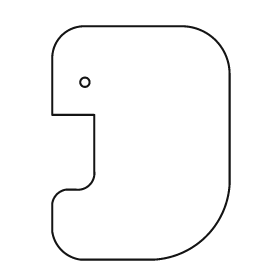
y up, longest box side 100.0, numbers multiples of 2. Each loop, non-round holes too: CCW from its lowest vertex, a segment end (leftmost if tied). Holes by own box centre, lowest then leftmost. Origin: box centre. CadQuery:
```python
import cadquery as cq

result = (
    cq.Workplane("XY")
    .moveTo(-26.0, -50.0)
    .lineTo(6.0, -50.0)
    .threePointArc((28.0, -40.0), (38.0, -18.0))
    .lineTo(38.0, 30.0)
    .threePointArc((32.0, 44.0), (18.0, 50.0))
    .lineTo(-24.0, 50.0)
    .threePointArc((-34.0, 46.0), (-38.0, 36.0))
    .lineTo(-38.0, 12.0)
    .lineTo(-20.0, 12.0)
    .lineTo(-20.0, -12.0)
    .threePointArc((-22.0, -18.0), (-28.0, -20.0))
    .lineTo(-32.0, -20.0)
    .threePointArc((-36.0, -22.0), (-38.0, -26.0))
    .lineTo(-38.0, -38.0)
    .threePointArc((-34.0, -46.0), (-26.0, -50.0))
    .close()
    .moveTo(-24.0, 26.0)
    .circle(2.0)
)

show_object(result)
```